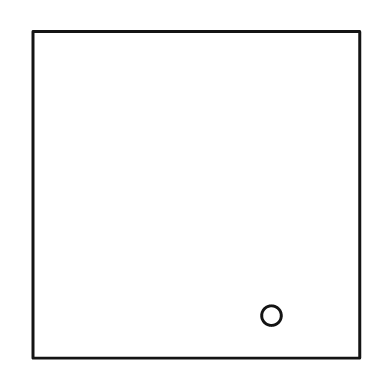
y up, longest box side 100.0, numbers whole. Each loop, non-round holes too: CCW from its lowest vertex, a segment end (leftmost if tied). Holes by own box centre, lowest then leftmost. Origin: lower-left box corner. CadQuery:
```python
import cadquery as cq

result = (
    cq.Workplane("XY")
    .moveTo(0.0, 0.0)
    .lineTo(100.0, 0.0)
    .lineTo(100.0, 100.0)
    .lineTo(0.0, 100.0)
    .close()
    .moveTo(73.0, 13.0)
    .circle(3.0)
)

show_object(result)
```